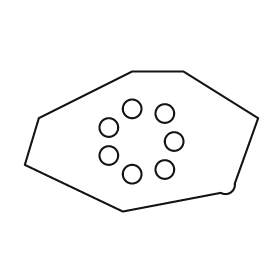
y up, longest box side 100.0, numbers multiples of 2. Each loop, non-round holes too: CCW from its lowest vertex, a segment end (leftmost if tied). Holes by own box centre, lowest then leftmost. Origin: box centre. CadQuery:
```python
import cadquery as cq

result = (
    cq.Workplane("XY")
    .moveTo(-8.0, -30.0)
    .lineTo(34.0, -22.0)
    .threePointArc((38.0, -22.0), (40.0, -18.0))
    .lineTo(50.0, 10.0)
    .lineTo(18.0, 30.0)
    .lineTo(-4.0, 30.0)
    .lineTo(-44.0, 10.0)
    .lineTo(-50.0, -10.0)
    .close()
    .moveTo(-4.0, -14.0)
    .circle(4.0)
    .moveTo(10.0, -12.0)
    .circle(4.0)
    .moveTo(-14.0, -6.0)
    .circle(4.0)
    .moveTo(14.0, 0.0)
    .circle(4.0)
    .moveTo(-14.0, 6.0)
    .circle(4.0)
    .moveTo(10.0, 12.0)
    .circle(4.0)
    .moveTo(-4.0, 14.0)
    .circle(4.0)
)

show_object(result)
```